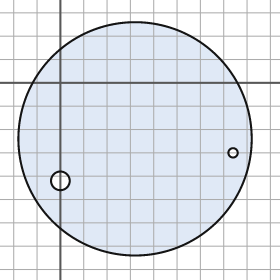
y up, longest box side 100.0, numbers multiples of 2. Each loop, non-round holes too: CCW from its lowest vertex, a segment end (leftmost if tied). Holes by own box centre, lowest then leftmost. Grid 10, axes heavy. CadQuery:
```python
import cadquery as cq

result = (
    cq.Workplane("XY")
    .moveTo(32.0, -24.0)
    .circle(50.0)
    .moveTo(0.0, -42.0)
    .circle(4.0)
    .moveTo(74.0, -30.0)
    .circle(2.0)
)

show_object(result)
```